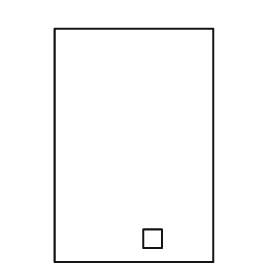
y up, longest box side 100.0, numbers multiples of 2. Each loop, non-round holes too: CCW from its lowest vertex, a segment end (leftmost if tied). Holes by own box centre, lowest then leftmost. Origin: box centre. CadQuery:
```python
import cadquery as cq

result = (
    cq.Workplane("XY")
    .moveTo(-34.0, -50.0)
    .lineTo(34.0, -50.0)
    .lineTo(34.0, 50.0)
    .lineTo(-34.0, 50.0)
    .close()
    .moveTo(4.0, -44.0)
    .lineTo(12.0, -44.0)
    .lineTo(12.0, -36.0)
    .lineTo(4.0, -36.0)
    .close()
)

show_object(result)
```